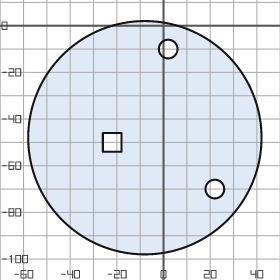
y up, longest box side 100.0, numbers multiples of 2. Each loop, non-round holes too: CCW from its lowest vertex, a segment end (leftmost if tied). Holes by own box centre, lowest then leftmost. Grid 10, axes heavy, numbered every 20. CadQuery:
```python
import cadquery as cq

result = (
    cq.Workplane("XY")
    .moveTo(-8.0, -48.0)
    .circle(50.0)
    .moveTo(22.0, -70.0)
    .circle(4.0)
    .moveTo(-26.0, -54.0)
    .lineTo(-18.0, -54.0)
    .lineTo(-18.0, -46.0)
    .lineTo(-26.0, -46.0)
    .close()
    .moveTo(2.0, -10.0)
    .circle(4.0)
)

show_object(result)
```